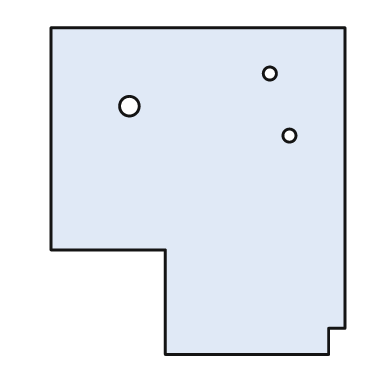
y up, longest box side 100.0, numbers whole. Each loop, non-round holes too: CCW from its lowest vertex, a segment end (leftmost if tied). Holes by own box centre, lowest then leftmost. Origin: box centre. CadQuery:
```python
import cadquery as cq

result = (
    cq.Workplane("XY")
    .moveTo(-10.0, -50.0)
    .lineTo(40.0, -50.0)
    .lineTo(40.0, -42.0)
    .lineTo(45.0, -42.0)
    .lineTo(45.0, 50.0)
    .lineTo(-45.0, 50.0)
    .lineTo(-45.0, -18.0)
    .lineTo(-10.0, -18.0)
    .close()
    .moveTo(28.0, 17.0)
    .circle(2.0)
    .moveTo(-21.0, 26.0)
    .circle(3.0)
    .moveTo(22.0, 36.0)
    .circle(2.0)
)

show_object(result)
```